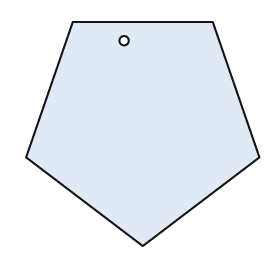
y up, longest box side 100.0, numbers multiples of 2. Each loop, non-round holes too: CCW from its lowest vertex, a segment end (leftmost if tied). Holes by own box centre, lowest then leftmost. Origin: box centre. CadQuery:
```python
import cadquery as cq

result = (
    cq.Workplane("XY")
    .moveTo(0.0, -48.0)
    .lineTo(50.0, -10.0)
    .lineTo(30.0, 48.0)
    .lineTo(-30.0, 48.0)
    .lineTo(-50.0, -10.0)
    .close()
    .moveTo(-8.0, 40.0)
    .circle(2.0)
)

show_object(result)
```